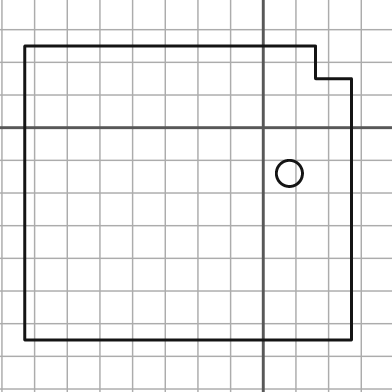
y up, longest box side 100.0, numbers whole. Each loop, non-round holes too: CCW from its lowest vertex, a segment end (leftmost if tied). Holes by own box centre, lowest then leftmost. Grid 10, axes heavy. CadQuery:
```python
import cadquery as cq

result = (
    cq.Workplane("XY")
    .moveTo(-73.0, -65.0)
    .lineTo(27.0, -65.0)
    .lineTo(27.0, 15.0)
    .lineTo(16.0, 15.0)
    .lineTo(16.0, 25.0)
    .lineTo(-73.0, 25.0)
    .close()
    .moveTo(8.0, -14.0)
    .circle(4.0)
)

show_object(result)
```